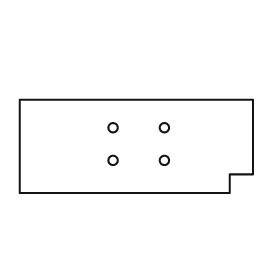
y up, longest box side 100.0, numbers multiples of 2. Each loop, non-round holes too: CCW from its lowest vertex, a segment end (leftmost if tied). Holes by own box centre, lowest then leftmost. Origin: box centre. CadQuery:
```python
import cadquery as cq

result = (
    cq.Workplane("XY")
    .moveTo(-50.0, -20.0)
    .lineTo(40.0, -20.0)
    .lineTo(40.0, -12.0)
    .lineTo(50.0, -12.0)
    .lineTo(50.0, 20.0)
    .lineTo(-50.0, 20.0)
    .close()
    .moveTo(-10.0, -6.0)
    .circle(2.0)
    .moveTo(12.0, -6.0)
    .circle(2.0)
    .moveTo(-10.0, 8.0)
    .circle(2.0)
    .moveTo(12.0, 8.0)
    .circle(2.0)
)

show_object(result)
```